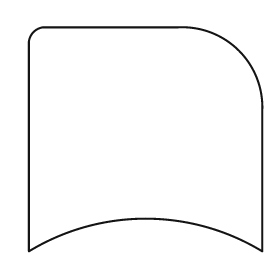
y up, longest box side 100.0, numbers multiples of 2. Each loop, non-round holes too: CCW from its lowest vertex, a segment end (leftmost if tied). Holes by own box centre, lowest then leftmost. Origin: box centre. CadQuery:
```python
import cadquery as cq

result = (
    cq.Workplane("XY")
    .moveTo(-50.0, -48.0)
    .threePointArc((0.0, -34.0), (50.0, -48.0))
    .lineTo(50.0, 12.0)
    .threePointArc((40.0, 38.0), (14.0, 48.0))
    .lineTo(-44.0, 48.0)
    .threePointArc((-48.0, 46.0), (-50.0, 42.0))
    .close()
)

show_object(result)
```